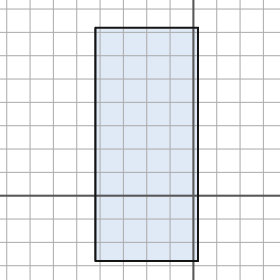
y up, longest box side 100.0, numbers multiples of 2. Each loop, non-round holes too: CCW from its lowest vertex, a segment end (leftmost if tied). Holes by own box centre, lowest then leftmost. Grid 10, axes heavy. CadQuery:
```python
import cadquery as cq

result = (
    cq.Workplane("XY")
    .moveTo(-42.0, -28.0)
    .lineTo(2.0, -28.0)
    .lineTo(2.0, 72.0)
    .lineTo(-42.0, 72.0)
    .close()
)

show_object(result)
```